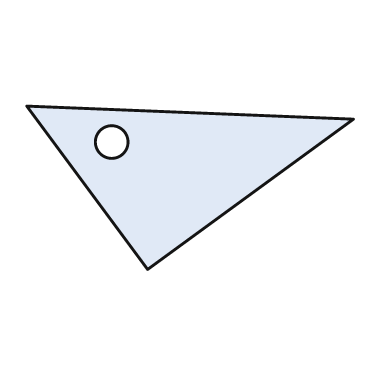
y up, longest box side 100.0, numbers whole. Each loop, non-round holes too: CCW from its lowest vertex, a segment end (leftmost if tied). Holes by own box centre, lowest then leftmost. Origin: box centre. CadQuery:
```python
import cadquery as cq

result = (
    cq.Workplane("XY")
    .moveTo(-13.0, -25.0)
    .lineTo(50.0, 21.0)
    .lineTo(-50.0, 25.0)
    .close()
    .moveTo(-24.0, 14.0)
    .circle(5.0)
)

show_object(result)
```